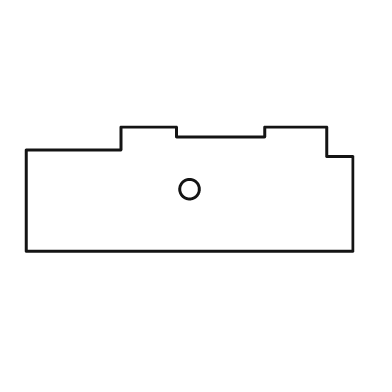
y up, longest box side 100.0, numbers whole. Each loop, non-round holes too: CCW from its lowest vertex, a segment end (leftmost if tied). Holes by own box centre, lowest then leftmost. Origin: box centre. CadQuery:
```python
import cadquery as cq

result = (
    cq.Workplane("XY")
    .moveTo(-50.0, -19.0)
    .lineTo(50.0, -19.0)
    .lineTo(50.0, 10.0)
    .lineTo(42.0, 10.0)
    .lineTo(42.0, 19.0)
    .lineTo(23.0, 19.0)
    .lineTo(23.0, 16.0)
    .lineTo(-4.0, 16.0)
    .lineTo(-4.0, 19.0)
    .lineTo(-21.0, 19.0)
    .lineTo(-21.0, 12.0)
    .lineTo(-50.0, 12.0)
    .close()
    .moveTo(0.0, 0.0)
    .circle(3.0)
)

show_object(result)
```